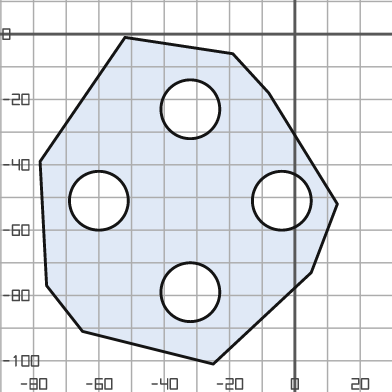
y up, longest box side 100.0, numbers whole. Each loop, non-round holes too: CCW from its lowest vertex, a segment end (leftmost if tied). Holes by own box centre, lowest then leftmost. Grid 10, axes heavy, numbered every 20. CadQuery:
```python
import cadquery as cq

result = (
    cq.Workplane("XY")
    .moveTo(-25.0, -101.0)
    .lineTo(5.0, -73.0)
    .lineTo(13.0, -52.0)
    .lineTo(-8.0, -18.0)
    .lineTo(-19.0, -6.0)
    .lineTo(-52.0, -1.0)
    .lineTo(-78.0, -39.0)
    .lineTo(-76.0, -77.0)
    .lineTo(-65.0, -91.0)
    .close()
    .moveTo(-32.0, -79.0)
    .circle(9.0)
    .moveTo(-60.0, -51.0)
    .circle(9.0)
    .moveTo(-4.0, -51.0)
    .circle(9.0)
    .moveTo(-32.0, -23.0)
    .circle(9.0)
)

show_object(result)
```